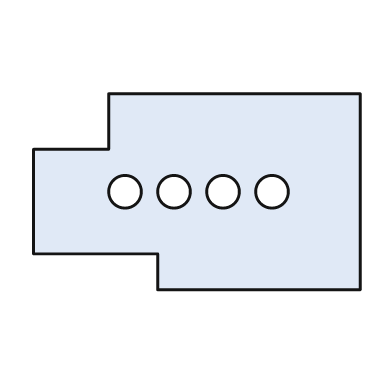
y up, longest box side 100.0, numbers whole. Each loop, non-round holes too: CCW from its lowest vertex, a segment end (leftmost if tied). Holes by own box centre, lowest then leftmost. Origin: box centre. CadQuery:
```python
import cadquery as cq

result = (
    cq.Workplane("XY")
    .moveTo(-12.0, -30.0)
    .lineTo(50.0, -30.0)
    .lineTo(50.0, 30.0)
    .lineTo(-27.0, 30.0)
    .lineTo(-27.0, 13.0)
    .lineTo(-50.0, 13.0)
    .lineTo(-50.0, -19.0)
    .lineTo(-12.0, -19.0)
    .close()
    .moveTo(-22.0, 0.0)
    .circle(5.0)
    .moveTo(-7.0, 0.0)
    .circle(5.0)
    .moveTo(8.0, 0.0)
    .circle(5.0)
    .moveTo(23.0, 0.0)
    .circle(5.0)
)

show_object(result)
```